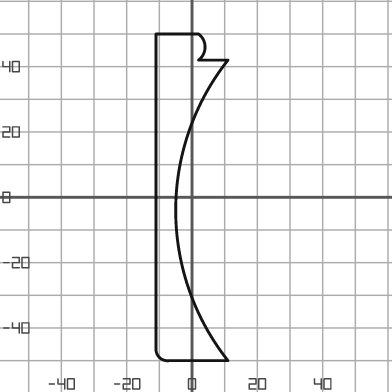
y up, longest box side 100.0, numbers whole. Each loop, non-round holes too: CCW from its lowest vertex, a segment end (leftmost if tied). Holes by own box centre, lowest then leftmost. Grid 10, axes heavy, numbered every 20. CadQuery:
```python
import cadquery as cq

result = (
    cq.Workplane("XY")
    .moveTo(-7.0, -50.0)
    .lineTo(11.0, -50.0)
    .threePointArc((-5.0, -4.0), (11.0, 42.0))
    .lineTo(2.0, 42.0)
    .threePointArc((4.0, 46.0), (2.0, 50.0))
    .lineTo(-11.0, 50.0)
    .lineTo(-11.0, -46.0)
    .threePointArc((-10.0, -49.0), (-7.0, -50.0))
    .close()
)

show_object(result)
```